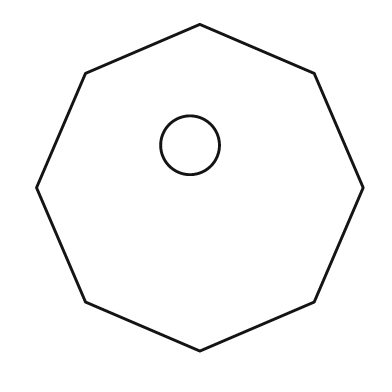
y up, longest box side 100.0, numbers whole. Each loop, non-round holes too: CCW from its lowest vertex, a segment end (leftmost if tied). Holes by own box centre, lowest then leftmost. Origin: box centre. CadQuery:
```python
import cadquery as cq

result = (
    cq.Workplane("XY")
    .moveTo(0.0, -50.0)
    .lineTo(35.0, -35.0)
    .lineTo(50.0, 0.0)
    .lineTo(35.0, 35.0)
    .lineTo(0.0, 50.0)
    .lineTo(-35.0, 35.0)
    .lineTo(-50.0, 0.0)
    .lineTo(-35.0, -35.0)
    .close()
    .moveTo(-3.0, 13.0)
    .circle(9.0)
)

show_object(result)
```